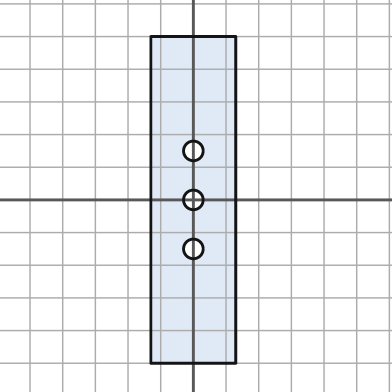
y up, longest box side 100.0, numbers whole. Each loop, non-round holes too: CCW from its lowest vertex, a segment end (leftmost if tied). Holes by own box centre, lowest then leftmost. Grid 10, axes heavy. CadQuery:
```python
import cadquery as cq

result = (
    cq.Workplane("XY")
    .moveTo(-13.0, -50.0)
    .lineTo(13.0, -50.0)
    .lineTo(13.0, 50.0)
    .lineTo(-13.0, 50.0)
    .close()
    .moveTo(0.0, -15.0)
    .circle(3.0)
    .moveTo(0.0, 0.0)
    .circle(3.0)
    .moveTo(0.0, 15.0)
    .circle(3.0)
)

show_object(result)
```